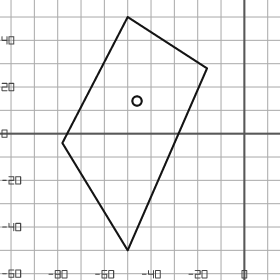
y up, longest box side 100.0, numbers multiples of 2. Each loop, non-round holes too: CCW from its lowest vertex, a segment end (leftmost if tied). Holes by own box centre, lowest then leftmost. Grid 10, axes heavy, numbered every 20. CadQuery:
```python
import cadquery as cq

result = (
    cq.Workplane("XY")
    .moveTo(-50.0, -50.0)
    .lineTo(-16.0, 28.0)
    .lineTo(-50.0, 50.0)
    .lineTo(-78.0, -4.0)
    .close()
    .moveTo(-46.0, 14.0)
    .circle(2.0)
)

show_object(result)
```